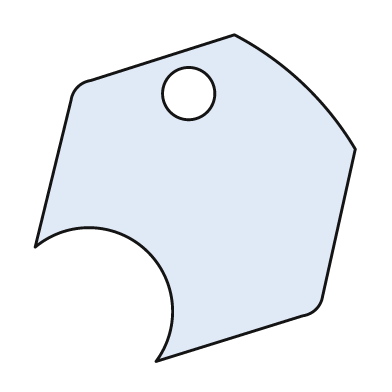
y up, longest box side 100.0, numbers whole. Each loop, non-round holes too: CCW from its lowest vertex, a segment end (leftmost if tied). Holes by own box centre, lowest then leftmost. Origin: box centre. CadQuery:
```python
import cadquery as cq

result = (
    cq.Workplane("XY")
    .moveTo(-12.0, -50.0)
    .lineTo(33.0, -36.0)
    .threePointArc((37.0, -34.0), (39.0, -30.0))
    .lineTo(49.0, 15.0)
    .threePointArc((33.0, 35.0), (12.0, 50.0))
    .lineTo(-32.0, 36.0)
    .threePointArc((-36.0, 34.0), (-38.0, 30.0))
    .lineTo(-49.0, -15.0)
    .threePointArc((-15.0, -16.0), (-12.0, -50.0))
    .close()
    .moveTo(-2.0, 32.0)
    .circle(8.0)
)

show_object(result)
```